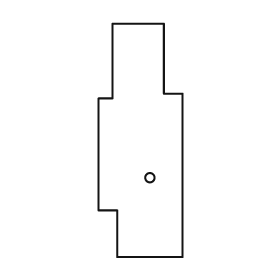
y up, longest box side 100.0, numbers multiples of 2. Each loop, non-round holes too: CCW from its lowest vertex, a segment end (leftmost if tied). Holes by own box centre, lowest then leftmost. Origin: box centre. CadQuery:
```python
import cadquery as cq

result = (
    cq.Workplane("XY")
    .moveTo(-10.0, -50.0)
    .lineTo(18.0, -50.0)
    .lineTo(18.0, 20.0)
    .lineTo(10.0, 20.0)
    .lineTo(10.0, 50.0)
    .lineTo(-12.0, 50.0)
    .lineTo(-12.0, 18.0)
    .lineTo(-18.0, 18.0)
    .lineTo(-18.0, -30.0)
    .lineTo(-10.0, -30.0)
    .close()
    .moveTo(4.0, -16.0)
    .circle(2.0)
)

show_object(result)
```